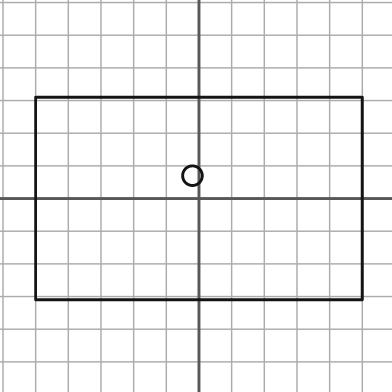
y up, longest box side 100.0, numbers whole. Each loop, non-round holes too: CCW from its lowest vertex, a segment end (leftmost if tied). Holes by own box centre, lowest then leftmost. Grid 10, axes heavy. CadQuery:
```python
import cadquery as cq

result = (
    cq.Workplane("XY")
    .moveTo(-50.0, -31.0)
    .lineTo(50.0, -31.0)
    .lineTo(50.0, 31.0)
    .lineTo(-50.0, 31.0)
    .close()
    .moveTo(-2.0, 7.0)
    .circle(3.0)
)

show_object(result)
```